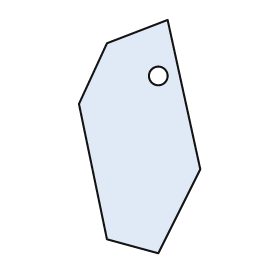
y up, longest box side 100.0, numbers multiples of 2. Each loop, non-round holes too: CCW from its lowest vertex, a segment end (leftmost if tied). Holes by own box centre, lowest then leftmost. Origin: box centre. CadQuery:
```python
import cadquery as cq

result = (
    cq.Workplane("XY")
    .moveTo(8.0, -50.0)
    .lineTo(26.0, -14.0)
    .lineTo(12.0, 50.0)
    .lineTo(-14.0, 40.0)
    .lineTo(-26.0, 14.0)
    .lineTo(-14.0, -44.0)
    .close()
    .moveTo(8.0, 26.0)
    .circle(4.0)
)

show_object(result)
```